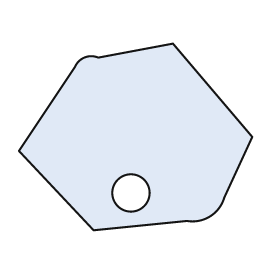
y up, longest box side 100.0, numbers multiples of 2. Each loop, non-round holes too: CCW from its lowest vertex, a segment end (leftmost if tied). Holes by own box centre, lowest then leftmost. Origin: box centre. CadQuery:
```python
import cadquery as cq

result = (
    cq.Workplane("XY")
    .moveTo(-18.0, -40.0)
    .lineTo(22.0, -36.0)
    .threePointArc((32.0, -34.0), (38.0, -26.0))
    .lineTo(50.0, 0.0)
    .lineTo(16.0, 40.0)
    .lineTo(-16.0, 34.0)
    .threePointArc((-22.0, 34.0), (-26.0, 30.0))
    .lineTo(-50.0, -6.0)
    .close()
    .moveTo(-2.0, -24.0)
    .circle(8.0)
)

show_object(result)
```